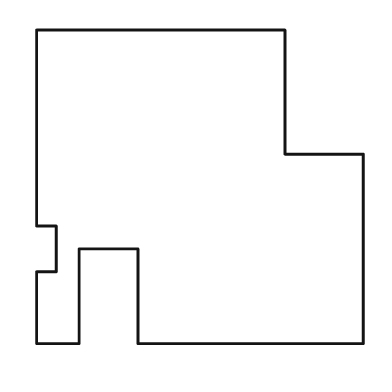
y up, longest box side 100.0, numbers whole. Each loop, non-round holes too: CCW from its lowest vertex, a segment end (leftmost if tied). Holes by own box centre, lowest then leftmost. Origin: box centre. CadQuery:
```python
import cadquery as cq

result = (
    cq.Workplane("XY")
    .moveTo(-50.0, -48.0)
    .lineTo(-37.0, -48.0)
    .lineTo(-37.0, -19.0)
    .lineTo(-19.0, -19.0)
    .lineTo(-19.0, -48.0)
    .lineTo(50.0, -48.0)
    .lineTo(50.0, 10.0)
    .lineTo(26.0, 10.0)
    .lineTo(26.0, 48.0)
    .lineTo(-50.0, 48.0)
    .lineTo(-50.0, -12.0)
    .lineTo(-44.0, -12.0)
    .lineTo(-44.0, -26.0)
    .lineTo(-50.0, -26.0)
    .close()
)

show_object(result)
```